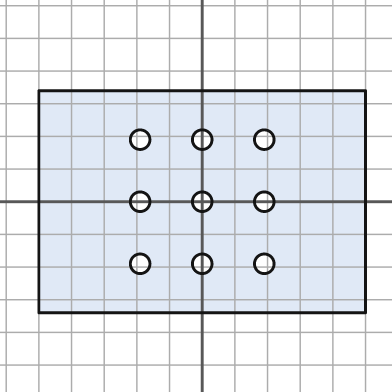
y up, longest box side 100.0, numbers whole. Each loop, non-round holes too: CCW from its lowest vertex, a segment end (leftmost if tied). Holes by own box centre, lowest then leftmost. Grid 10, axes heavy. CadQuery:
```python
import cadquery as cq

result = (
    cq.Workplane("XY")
    .moveTo(-50.0, -34.0)
    .lineTo(50.0, -34.0)
    .lineTo(50.0, 34.0)
    .lineTo(-50.0, 34.0)
    .close()
    .moveTo(-19.0, -19.0)
    .circle(3.0)
    .moveTo(0.0, -19.0)
    .circle(3.0)
    .moveTo(19.0, -19.0)
    .circle(3.0)
    .moveTo(-19.0, 0.0)
    .circle(3.0)
    .moveTo(0.0, 0.0)
    .circle(3.0)
    .moveTo(19.0, 0.0)
    .circle(3.0)
    .moveTo(-19.0, 19.0)
    .circle(3.0)
    .moveTo(0.0, 19.0)
    .circle(3.0)
    .moveTo(19.0, 19.0)
    .circle(3.0)
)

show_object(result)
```